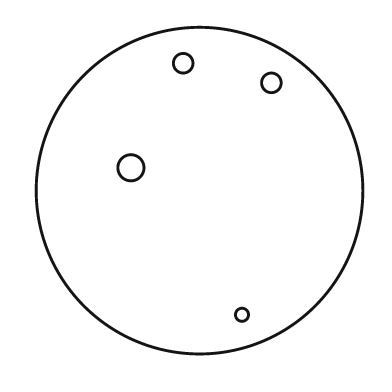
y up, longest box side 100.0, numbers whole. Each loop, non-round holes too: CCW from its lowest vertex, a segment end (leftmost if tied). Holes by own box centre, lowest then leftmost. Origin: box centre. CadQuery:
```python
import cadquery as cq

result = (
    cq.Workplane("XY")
    .moveTo(0.0, 0.0)
    .circle(50.0)
    .moveTo(13.0, -38.0)
    .circle(2.0)
    .moveTo(-21.0, 7.0)
    .circle(4.0)
    .moveTo(22.0, 33.0)
    .circle(3.0)
    .moveTo(-5.0, 39.0)
    .circle(3.0)
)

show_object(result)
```